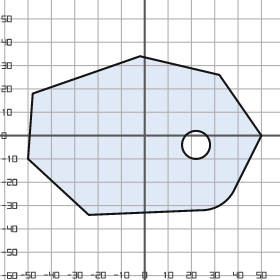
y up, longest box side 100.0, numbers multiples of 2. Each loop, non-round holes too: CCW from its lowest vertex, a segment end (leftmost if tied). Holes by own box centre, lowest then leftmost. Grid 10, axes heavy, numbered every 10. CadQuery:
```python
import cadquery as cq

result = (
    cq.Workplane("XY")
    .moveTo(-24.0, -34.0)
    .lineTo(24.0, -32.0)
    .threePointArc((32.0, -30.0), (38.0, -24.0))
    .lineTo(50.0, 0.0)
    .lineTo(32.0, 26.0)
    .lineTo(-2.0, 34.0)
    .lineTo(-48.0, 18.0)
    .lineTo(-50.0, -10.0)
    .close()
    .moveTo(22.0, -4.0)
    .circle(6.0)
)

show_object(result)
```